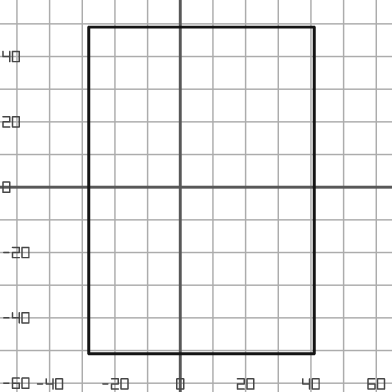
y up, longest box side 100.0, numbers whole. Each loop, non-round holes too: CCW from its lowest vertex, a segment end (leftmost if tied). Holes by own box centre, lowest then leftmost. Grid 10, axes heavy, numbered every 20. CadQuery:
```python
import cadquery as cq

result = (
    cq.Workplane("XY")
    .moveTo(-28.0, -51.0)
    .lineTo(41.0, -51.0)
    .lineTo(41.0, 49.0)
    .lineTo(-28.0, 49.0)
    .close()
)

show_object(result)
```